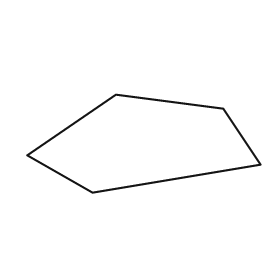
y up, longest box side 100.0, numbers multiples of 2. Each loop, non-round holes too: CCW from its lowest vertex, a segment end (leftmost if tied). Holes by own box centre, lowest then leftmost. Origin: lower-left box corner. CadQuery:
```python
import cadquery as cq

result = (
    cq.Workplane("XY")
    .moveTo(28.0, 0.0)
    .lineTo(100.0, 12.0)
    .lineTo(84.0, 36.0)
    .lineTo(38.0, 42.0)
    .lineTo(0.0, 16.0)
    .close()
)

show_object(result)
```